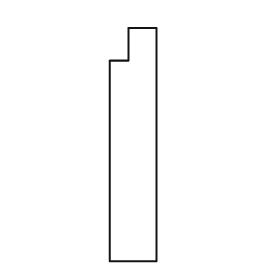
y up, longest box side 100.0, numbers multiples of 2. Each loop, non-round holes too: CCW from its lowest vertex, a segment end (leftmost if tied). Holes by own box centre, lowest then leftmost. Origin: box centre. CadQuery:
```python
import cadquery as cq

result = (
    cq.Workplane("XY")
    .moveTo(-10.0, -50.0)
    .lineTo(10.0, -50.0)
    .lineTo(10.0, 50.0)
    .lineTo(-2.0, 50.0)
    .lineTo(-2.0, 36.0)
    .lineTo(-10.0, 36.0)
    .close()
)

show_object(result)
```